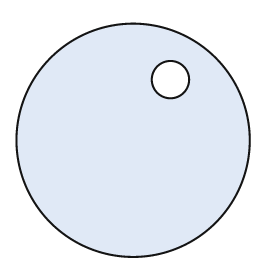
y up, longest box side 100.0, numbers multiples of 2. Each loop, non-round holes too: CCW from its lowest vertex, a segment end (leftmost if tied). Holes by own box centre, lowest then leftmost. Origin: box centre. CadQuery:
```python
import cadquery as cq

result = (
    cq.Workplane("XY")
    .moveTo(0.0, 0.0)
    .circle(50.0)
    .moveTo(16.0, 26.0)
    .circle(8.0)
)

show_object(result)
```